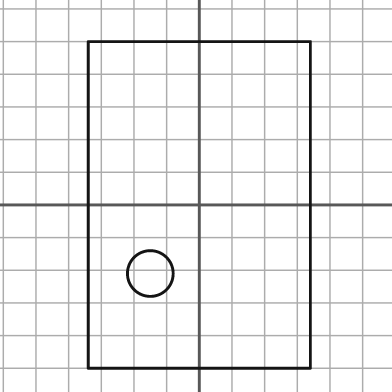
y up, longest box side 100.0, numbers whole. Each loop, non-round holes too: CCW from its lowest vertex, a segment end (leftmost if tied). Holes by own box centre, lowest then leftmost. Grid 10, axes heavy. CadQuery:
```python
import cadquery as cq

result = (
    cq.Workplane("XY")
    .moveTo(-34.0, -50.0)
    .lineTo(34.0, -50.0)
    .lineTo(34.0, 50.0)
    .lineTo(-34.0, 50.0)
    .close()
    .moveTo(-15.0, -21.0)
    .circle(7.0)
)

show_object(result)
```